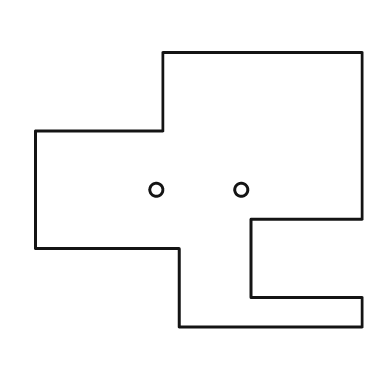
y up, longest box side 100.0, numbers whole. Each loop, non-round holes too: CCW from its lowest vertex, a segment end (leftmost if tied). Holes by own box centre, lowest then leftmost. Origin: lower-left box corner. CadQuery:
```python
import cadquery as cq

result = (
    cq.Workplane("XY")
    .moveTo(44.0, 0.0)
    .lineTo(100.0, 0.0)
    .lineTo(100.0, 9.0)
    .lineTo(66.0, 9.0)
    .lineTo(66.0, 33.0)
    .lineTo(100.0, 33.0)
    .lineTo(100.0, 84.0)
    .lineTo(39.0, 84.0)
    .lineTo(39.0, 60.0)
    .lineTo(0.0, 60.0)
    .lineTo(0.0, 24.0)
    .lineTo(44.0, 24.0)
    .close()
    .moveTo(37.0, 42.0)
    .circle(2.0)
    .moveTo(63.0, 42.0)
    .circle(2.0)
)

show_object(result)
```